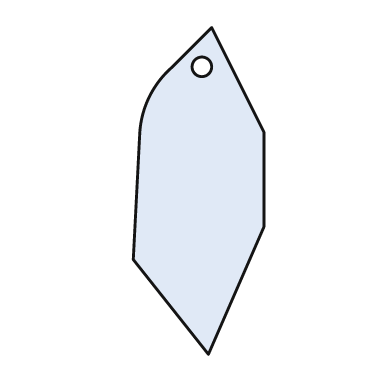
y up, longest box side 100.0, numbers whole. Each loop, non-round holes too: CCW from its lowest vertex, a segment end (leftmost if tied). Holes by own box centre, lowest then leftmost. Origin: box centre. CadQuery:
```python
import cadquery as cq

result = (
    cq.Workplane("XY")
    .moveTo(3.0, -50.0)
    .lineTo(20.0, -11.0)
    .lineTo(20.0, 18.0)
    .lineTo(4.0, 50.0)
    .lineTo(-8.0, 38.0)
    .threePointArc((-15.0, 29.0), (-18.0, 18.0))
    .lineTo(-20.0, -21.0)
    .close()
    .moveTo(1.0, 38.0)
    .circle(3.0)
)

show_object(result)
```